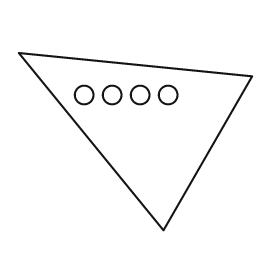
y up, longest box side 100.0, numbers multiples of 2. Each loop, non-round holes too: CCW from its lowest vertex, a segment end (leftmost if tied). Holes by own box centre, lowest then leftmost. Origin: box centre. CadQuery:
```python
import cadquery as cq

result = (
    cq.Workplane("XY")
    .moveTo(12.0, -38.0)
    .lineTo(50.0, 28.0)
    .lineTo(-50.0, 38.0)
    .close()
    .moveTo(-22.0, 20.0)
    .circle(4.0)
    .moveTo(-10.0, 20.0)
    .circle(4.0)
    .moveTo(2.0, 20.0)
    .circle(4.0)
    .moveTo(14.0, 20.0)
    .circle(4.0)
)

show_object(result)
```